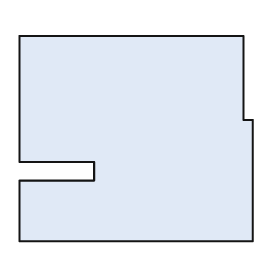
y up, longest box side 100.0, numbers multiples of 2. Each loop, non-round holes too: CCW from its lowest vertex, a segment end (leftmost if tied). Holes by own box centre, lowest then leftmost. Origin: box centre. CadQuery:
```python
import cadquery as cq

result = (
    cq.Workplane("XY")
    .moveTo(-50.0, -44.0)
    .lineTo(50.0, -44.0)
    .lineTo(50.0, 8.0)
    .lineTo(46.0, 8.0)
    .lineTo(46.0, 44.0)
    .lineTo(-50.0, 44.0)
    .lineTo(-50.0, -10.0)
    .lineTo(-18.0, -10.0)
    .lineTo(-18.0, -18.0)
    .lineTo(-50.0, -18.0)
    .close()
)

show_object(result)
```